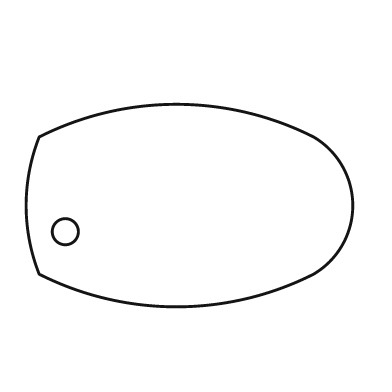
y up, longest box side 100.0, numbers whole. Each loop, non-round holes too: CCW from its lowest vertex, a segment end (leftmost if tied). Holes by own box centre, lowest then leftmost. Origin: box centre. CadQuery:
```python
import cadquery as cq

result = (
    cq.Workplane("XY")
    .moveTo(-46.0, -21.0)
    .threePointArc((-4.0, -31.0), (38.0, -21.0))
    .threePointArc((50.0, 0.0), (38.0, 21.0))
    .threePointArc((-4.0, 31.0), (-46.0, 21.0))
    .threePointArc((-50.0, 0.0), (-46.0, -21.0))
    .close()
    .moveTo(-38.0, -8.0)
    .circle(4.0)
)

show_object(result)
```